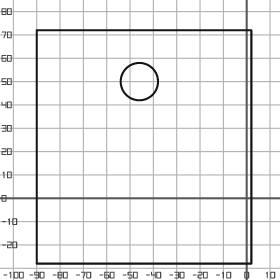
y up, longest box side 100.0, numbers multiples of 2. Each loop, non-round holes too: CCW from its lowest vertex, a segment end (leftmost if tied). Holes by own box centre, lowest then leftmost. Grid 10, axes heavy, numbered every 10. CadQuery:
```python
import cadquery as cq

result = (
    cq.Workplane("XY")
    .moveTo(-90.0, -28.0)
    .lineTo(2.0, -28.0)
    .lineTo(2.0, 72.0)
    .lineTo(-90.0, 72.0)
    .close()
    .moveTo(-46.0, 50.0)
    .circle(8.0)
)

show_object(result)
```